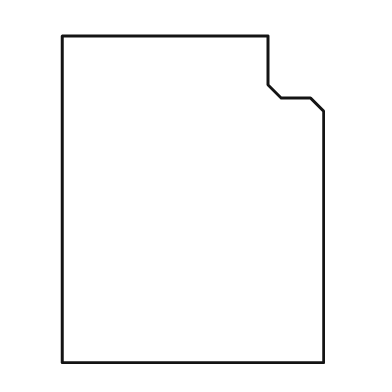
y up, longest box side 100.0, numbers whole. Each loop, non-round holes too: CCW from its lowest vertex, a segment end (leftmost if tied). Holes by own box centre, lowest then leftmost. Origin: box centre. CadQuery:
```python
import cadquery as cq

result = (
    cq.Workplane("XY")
    .moveTo(-40.0, -50.0)
    .lineTo(40.0, -50.0)
    .lineTo(40.0, 27.0)
    .lineTo(36.0, 31.0)
    .lineTo(27.0, 31.0)
    .lineTo(23.0, 35.0)
    .lineTo(23.0, 50.0)
    .lineTo(-40.0, 50.0)
    .close()
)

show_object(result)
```